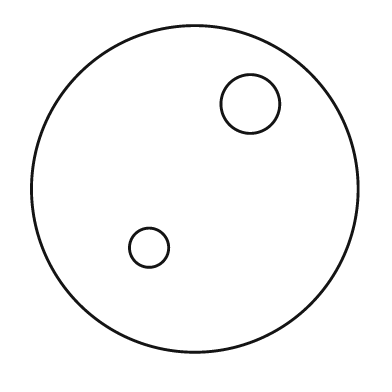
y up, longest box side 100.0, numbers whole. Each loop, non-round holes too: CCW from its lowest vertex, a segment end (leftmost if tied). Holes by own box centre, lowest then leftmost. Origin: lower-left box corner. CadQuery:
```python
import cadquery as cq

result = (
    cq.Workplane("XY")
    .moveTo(50.0, 50.0)
    .circle(50.0)
    .moveTo(36.0, 32.0)
    .circle(6.0)
    .moveTo(67.0, 76.0)
    .circle(9.0)
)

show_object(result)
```